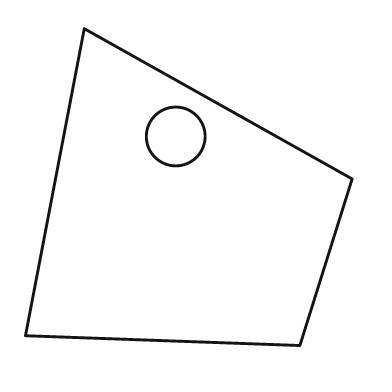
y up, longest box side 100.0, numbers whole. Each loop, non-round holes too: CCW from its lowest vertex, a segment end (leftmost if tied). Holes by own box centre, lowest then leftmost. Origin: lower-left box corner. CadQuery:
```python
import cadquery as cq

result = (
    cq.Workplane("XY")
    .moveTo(84.0, 0.0)
    .lineTo(100.0, 51.0)
    .lineTo(18.0, 97.0)
    .lineTo(0.0, 3.0)
    .close()
    .moveTo(46.0, 64.0)
    .circle(9.0)
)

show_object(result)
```